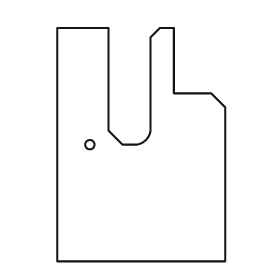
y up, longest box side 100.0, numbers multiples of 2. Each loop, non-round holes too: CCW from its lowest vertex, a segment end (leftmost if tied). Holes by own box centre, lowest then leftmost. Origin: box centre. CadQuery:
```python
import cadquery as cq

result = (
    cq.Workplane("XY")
    .moveTo(-36.0, -50.0)
    .lineTo(36.0, -50.0)
    .lineTo(36.0, 16.0)
    .lineTo(30.0, 22.0)
    .lineTo(14.0, 22.0)
    .lineTo(14.0, 50.0)
    .lineTo(8.0, 50.0)
    .lineTo(4.0, 46.0)
    .lineTo(4.0, 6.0)
    .threePointArc((2.0, 2.0), (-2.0, 0.0))
    .lineTo(-8.0, 0.0)
    .lineTo(-14.0, 6.0)
    .lineTo(-14.0, 50.0)
    .lineTo(-36.0, 50.0)
    .close()
    .moveTo(-22.0, 0.0)
    .circle(2.0)
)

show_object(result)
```